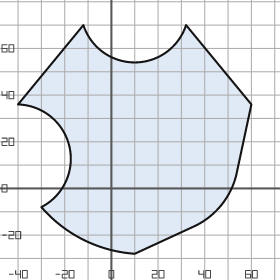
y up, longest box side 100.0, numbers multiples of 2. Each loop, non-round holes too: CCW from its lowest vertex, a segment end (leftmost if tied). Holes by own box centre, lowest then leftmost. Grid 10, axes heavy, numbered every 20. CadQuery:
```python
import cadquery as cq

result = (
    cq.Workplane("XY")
    .moveTo(10.0, -28.0)
    .lineTo(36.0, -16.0)
    .threePointArc((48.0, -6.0), (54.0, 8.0))
    .lineTo(60.0, 36.0)
    .lineTo(32.0, 70.0)
    .threePointArc((10.0, 54.0), (-12.0, 70.0))
    .lineTo(-40.0, 36.0)
    .threePointArc((-18.0, 18.0), (-30.0, -8.0))
    .threePointArc((-12.0, -22.0), (10.0, -28.0))
    .close()
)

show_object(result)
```